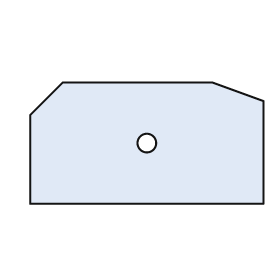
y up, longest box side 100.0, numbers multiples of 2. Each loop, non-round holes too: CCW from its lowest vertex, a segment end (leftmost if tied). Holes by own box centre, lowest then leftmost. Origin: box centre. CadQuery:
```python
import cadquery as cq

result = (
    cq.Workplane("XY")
    .moveTo(-50.0, -26.0)
    .lineTo(50.0, -26.0)
    .lineTo(50.0, 18.0)
    .lineTo(28.0, 26.0)
    .lineTo(-36.0, 26.0)
    .lineTo(-50.0, 12.0)
    .close()
    .moveTo(0.0, 0.0)
    .circle(4.0)
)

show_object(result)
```